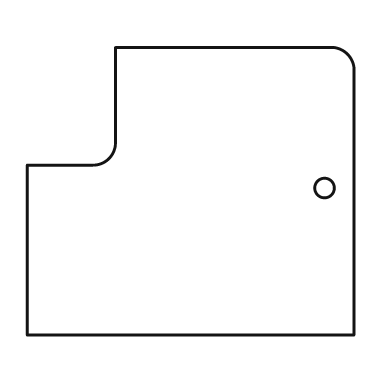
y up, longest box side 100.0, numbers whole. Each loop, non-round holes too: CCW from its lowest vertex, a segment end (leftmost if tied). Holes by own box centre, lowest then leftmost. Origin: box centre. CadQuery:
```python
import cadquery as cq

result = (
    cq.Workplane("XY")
    .moveTo(-50.0, -44.0)
    .lineTo(50.0, -44.0)
    .lineTo(50.0, 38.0)
    .threePointArc((48.0, 42.0), (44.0, 44.0))
    .lineTo(-23.0, 44.0)
    .lineTo(-23.0, 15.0)
    .threePointArc((-25.0, 10.0), (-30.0, 8.0))
    .lineTo(-50.0, 8.0)
    .close()
    .moveTo(41.0, 1.0)
    .circle(3.0)
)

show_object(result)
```